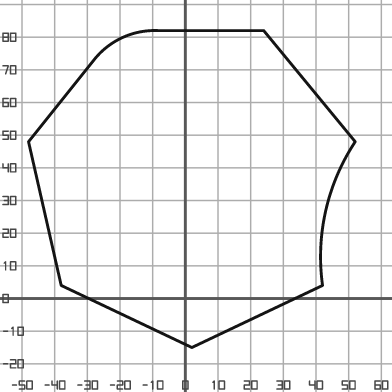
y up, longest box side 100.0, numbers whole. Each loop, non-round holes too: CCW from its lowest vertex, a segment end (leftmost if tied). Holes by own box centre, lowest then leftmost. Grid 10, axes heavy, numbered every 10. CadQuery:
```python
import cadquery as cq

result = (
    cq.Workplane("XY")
    .moveTo(2.0, -15.0)
    .lineTo(42.0, 4.0)
    .threePointArc((43.0, 27.0), (52.0, 48.0))
    .lineTo(24.0, 82.0)
    .lineTo(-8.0, 82.0)
    .threePointArc((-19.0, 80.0), (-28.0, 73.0))
    .lineTo(-48.0, 48.0)
    .lineTo(-38.0, 4.0)
    .close()
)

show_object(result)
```